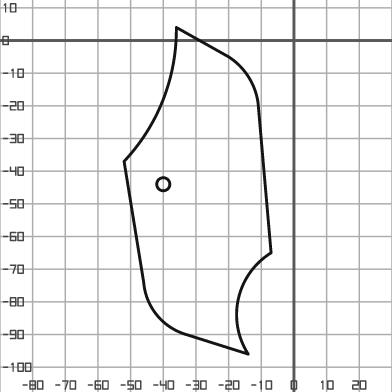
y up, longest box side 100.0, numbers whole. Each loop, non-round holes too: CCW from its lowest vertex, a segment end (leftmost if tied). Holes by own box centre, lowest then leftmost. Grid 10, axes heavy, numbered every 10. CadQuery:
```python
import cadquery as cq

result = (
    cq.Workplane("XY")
    .moveTo(-14.0, -96.0)
    .threePointArc((-17.0, -79.0), (-7.0, -65.0))
    .lineTo(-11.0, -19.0)
    .threePointArc((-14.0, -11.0), (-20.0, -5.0))
    .lineTo(-36.0, 4.0)
    .threePointArc((-40.0, -18.0), (-52.0, -37.0))
    .lineTo(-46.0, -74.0)
    .threePointArc((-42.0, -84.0), (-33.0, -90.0))
    .close()
    .moveTo(-40.0, -44.0)
    .circle(2.0)
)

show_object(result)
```